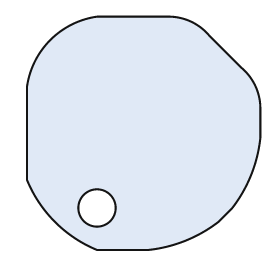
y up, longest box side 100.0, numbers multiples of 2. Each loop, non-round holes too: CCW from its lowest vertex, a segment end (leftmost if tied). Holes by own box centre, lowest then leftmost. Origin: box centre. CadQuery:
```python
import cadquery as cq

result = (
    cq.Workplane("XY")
    .moveTo(-20.0, -50.0)
    .lineTo(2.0, -50.0)
    .threePointArc((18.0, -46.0), (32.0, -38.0))
    .lineTo(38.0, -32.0)
    .threePointArc((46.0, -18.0), (50.0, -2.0))
    .lineTo(50.0, 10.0)
    .threePointArc((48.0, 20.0), (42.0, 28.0))
    .lineTo(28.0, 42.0)
    .threePointArc((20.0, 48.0), (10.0, 50.0))
    .lineTo(-20.0, 50.0)
    .threePointArc((-40.0, 40.0), (-50.0, 20.0))
    .lineTo(-50.0, -20.0)
    .threePointArc((-38.0, -38.0), (-20.0, -50.0))
    .close()
    .moveTo(-20.0, -32.0)
    .circle(8.0)
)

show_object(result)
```